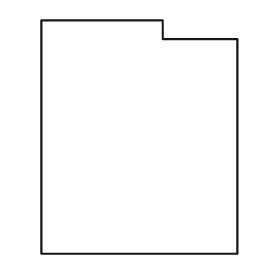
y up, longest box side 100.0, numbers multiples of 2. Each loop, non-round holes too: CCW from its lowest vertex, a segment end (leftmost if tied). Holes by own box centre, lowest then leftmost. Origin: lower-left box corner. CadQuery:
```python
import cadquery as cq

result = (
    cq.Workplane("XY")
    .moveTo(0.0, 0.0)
    .lineTo(84.0, 0.0)
    .lineTo(84.0, 92.0)
    .lineTo(52.0, 92.0)
    .lineTo(52.0, 100.0)
    .lineTo(0.0, 100.0)
    .close()
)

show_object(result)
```